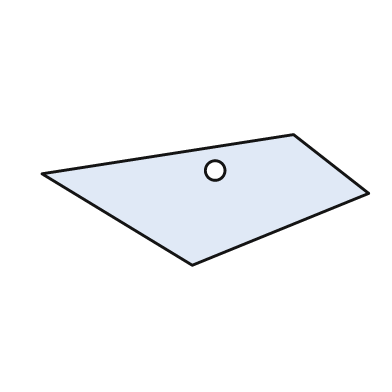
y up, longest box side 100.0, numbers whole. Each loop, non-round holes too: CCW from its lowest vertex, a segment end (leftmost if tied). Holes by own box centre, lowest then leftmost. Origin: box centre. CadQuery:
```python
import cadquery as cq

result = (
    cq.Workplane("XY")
    .moveTo(-4.0, -20.0)
    .lineTo(50.0, 2.0)
    .lineTo(27.0, 20.0)
    .lineTo(-50.0, 8.0)
    .close()
    .moveTo(3.0, 9.0)
    .circle(3.0)
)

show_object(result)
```